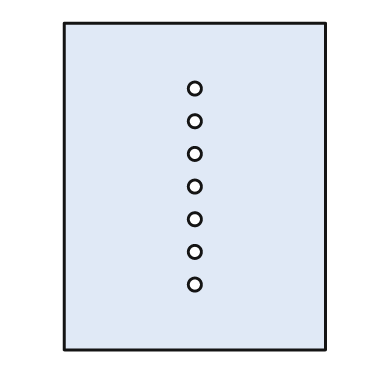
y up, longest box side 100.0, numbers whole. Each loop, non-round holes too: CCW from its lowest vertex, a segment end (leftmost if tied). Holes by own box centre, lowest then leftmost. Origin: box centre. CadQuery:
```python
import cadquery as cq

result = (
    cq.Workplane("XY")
    .moveTo(-40.0, -50.0)
    .lineTo(40.0, -50.0)
    .lineTo(40.0, 50.0)
    .lineTo(-40.0, 50.0)
    .close()
    .moveTo(0.0, -30.0)
    .circle(2.0)
    .moveTo(0.0, -20.0)
    .circle(2.0)
    .moveTo(0.0, -10.0)
    .circle(2.0)
    .moveTo(0.0, 0.0)
    .circle(2.0)
    .moveTo(0.0, 10.0)
    .circle(2.0)
    .moveTo(0.0, 20.0)
    .circle(2.0)
    .moveTo(0.0, 30.0)
    .circle(2.0)
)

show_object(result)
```